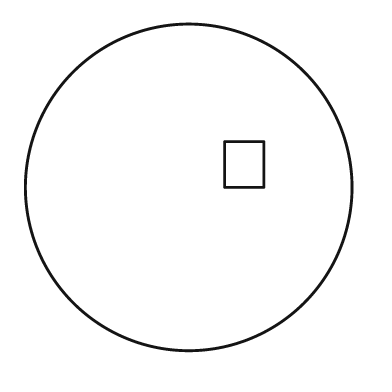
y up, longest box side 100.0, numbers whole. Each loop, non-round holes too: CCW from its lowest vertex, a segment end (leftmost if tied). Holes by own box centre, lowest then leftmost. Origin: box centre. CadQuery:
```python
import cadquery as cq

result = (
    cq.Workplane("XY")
    .moveTo(0.0, 0.0)
    .circle(50.0)
    .moveTo(11.0, 0.0)
    .lineTo(23.0, 0.0)
    .lineTo(23.0, 14.0)
    .lineTo(11.0, 14.0)
    .close()
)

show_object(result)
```